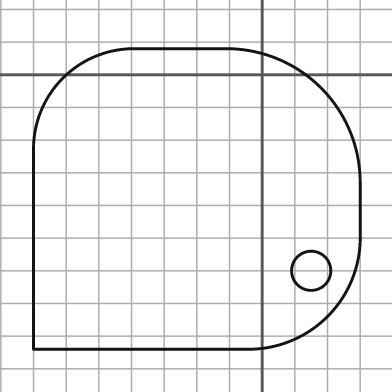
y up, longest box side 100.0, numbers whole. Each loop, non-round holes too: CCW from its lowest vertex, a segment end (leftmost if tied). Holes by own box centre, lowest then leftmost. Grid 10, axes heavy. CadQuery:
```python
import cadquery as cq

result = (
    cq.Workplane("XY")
    .moveTo(-70.0, -84.0)
    .lineTo(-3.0, -84.0)
    .threePointArc((20.0, -74.0), (30.0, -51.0))
    .lineTo(30.0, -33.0)
    .threePointArc((18.0, -4.0), (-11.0, 8.0))
    .lineTo(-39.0, 8.0)
    .threePointArc((-61.0, -1.0), (-70.0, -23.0))
    .close()
    .moveTo(15.0, -60.0)
    .circle(6.0)
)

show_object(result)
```